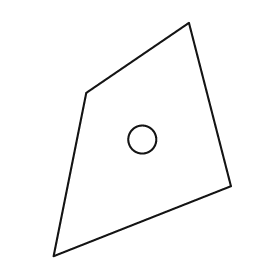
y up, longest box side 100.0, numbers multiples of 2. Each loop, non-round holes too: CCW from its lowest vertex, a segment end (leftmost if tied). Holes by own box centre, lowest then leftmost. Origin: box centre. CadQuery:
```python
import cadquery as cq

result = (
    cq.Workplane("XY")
    .moveTo(-38.0, -50.0)
    .lineTo(38.0, -20.0)
    .lineTo(20.0, 50.0)
    .lineTo(-24.0, 20.0)
    .close()
    .moveTo(0.0, 0.0)
    .circle(6.0)
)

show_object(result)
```